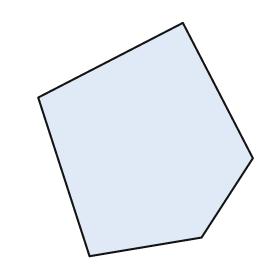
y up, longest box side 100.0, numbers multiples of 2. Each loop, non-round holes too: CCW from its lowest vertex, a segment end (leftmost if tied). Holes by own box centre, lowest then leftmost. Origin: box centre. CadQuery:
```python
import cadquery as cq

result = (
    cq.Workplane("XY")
    .moveTo(-24.0, -50.0)
    .lineTo(24.0, -42.0)
    .lineTo(46.0, -8.0)
    .lineTo(16.0, 50.0)
    .lineTo(-46.0, 18.0)
    .close()
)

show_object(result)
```